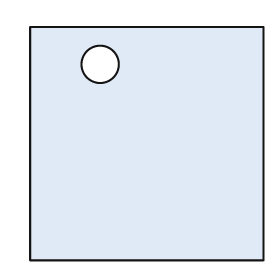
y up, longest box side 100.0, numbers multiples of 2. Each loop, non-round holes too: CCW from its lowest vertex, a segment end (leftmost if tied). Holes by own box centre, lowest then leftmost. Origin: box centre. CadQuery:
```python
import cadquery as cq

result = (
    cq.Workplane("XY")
    .moveTo(-50.0, -50.0)
    .lineTo(50.0, -50.0)
    .lineTo(50.0, 50.0)
    .lineTo(-50.0, 50.0)
    .close()
    .moveTo(-20.0, 34.0)
    .circle(8.0)
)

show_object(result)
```